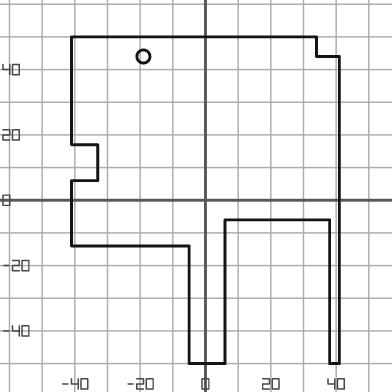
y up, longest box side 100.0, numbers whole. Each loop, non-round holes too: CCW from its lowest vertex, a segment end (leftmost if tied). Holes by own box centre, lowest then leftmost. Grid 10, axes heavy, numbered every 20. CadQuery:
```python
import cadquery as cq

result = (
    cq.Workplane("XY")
    .moveTo(-5.0, -50.0)
    .lineTo(6.0, -50.0)
    .lineTo(6.0, -6.0)
    .lineTo(38.0, -6.0)
    .lineTo(38.0, -50.0)
    .lineTo(41.0, -50.0)
    .lineTo(41.0, 44.0)
    .lineTo(34.0, 44.0)
    .lineTo(34.0, 50.0)
    .lineTo(-41.0, 50.0)
    .lineTo(-41.0, 17.0)
    .lineTo(-33.0, 17.0)
    .lineTo(-33.0, 6.0)
    .lineTo(-41.0, 6.0)
    .lineTo(-41.0, -14.0)
    .lineTo(-5.0, -14.0)
    .close()
    .moveTo(-19.0, 44.0)
    .circle(2.0)
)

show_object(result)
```